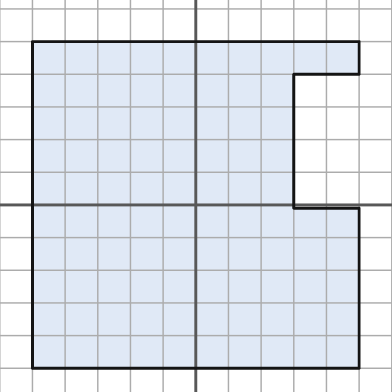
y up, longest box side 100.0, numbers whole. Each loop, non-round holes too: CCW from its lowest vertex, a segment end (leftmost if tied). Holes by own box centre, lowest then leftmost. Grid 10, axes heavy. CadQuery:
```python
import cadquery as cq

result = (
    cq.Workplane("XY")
    .moveTo(-50.0, -50.0)
    .lineTo(50.0, -50.0)
    .lineTo(50.0, -1.0)
    .lineTo(30.0, -1.0)
    .lineTo(30.0, 40.0)
    .lineTo(50.0, 40.0)
    .lineTo(50.0, 50.0)
    .lineTo(-50.0, 50.0)
    .close()
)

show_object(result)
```